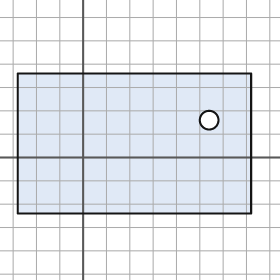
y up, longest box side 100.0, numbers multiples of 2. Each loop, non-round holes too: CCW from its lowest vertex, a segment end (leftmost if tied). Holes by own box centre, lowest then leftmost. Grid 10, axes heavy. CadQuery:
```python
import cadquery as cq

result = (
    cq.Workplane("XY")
    .moveTo(-28.0, -24.0)
    .lineTo(72.0, -24.0)
    .lineTo(72.0, 36.0)
    .lineTo(-28.0, 36.0)
    .close()
    .moveTo(54.0, 16.0)
    .circle(4.0)
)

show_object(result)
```